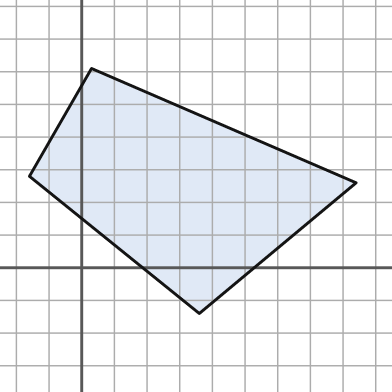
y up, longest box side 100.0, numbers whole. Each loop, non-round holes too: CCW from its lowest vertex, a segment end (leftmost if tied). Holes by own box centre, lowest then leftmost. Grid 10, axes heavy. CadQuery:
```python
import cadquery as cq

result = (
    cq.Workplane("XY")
    .moveTo(36.0, -14.0)
    .lineTo(84.0, 26.0)
    .lineTo(3.0, 61.0)
    .lineTo(-16.0, 28.0)
    .close()
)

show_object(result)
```